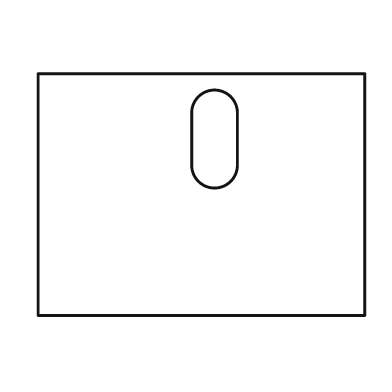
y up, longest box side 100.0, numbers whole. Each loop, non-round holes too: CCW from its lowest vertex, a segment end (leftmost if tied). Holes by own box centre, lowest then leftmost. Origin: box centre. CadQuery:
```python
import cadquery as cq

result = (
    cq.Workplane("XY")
    .moveTo(-50.0, -37.0)
    .lineTo(50.0, -37.0)
    .lineTo(50.0, 37.0)
    .lineTo(-50.0, 37.0)
    .close()
    .moveTo(-3.0, 9.0)
    .threePointArc((4.0, 2.0), (11.0, 9.0))
    .lineTo(11.0, 25.0)
    .threePointArc((4.0, 32.0), (-3.0, 25.0))
    .close()
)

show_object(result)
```